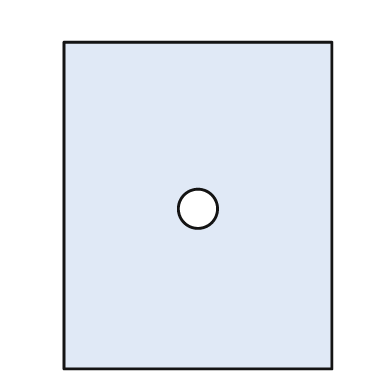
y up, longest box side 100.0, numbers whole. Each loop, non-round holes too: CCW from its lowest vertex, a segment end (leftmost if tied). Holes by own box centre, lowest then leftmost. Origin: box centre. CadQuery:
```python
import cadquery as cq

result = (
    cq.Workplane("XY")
    .moveTo(-41.0, -50.0)
    .lineTo(41.0, -50.0)
    .lineTo(41.0, 50.0)
    .lineTo(-41.0, 50.0)
    .close()
    .moveTo(0.0, -1.0)
    .circle(6.0)
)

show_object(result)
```